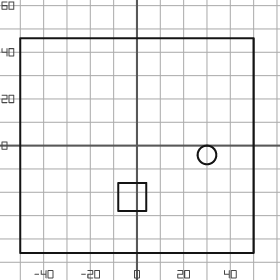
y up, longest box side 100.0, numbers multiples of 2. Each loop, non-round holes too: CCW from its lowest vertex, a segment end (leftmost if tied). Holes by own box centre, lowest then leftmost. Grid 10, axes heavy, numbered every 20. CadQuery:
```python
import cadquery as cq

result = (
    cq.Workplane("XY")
    .moveTo(-50.0, -46.0)
    .lineTo(50.0, -46.0)
    .lineTo(50.0, 46.0)
    .lineTo(-50.0, 46.0)
    .close()
    .moveTo(-8.0, -28.0)
    .lineTo(4.0, -28.0)
    .lineTo(4.0, -16.0)
    .lineTo(-8.0, -16.0)
    .close()
    .moveTo(30.0, -4.0)
    .circle(4.0)
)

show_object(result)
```